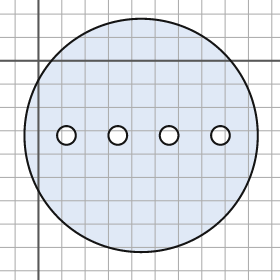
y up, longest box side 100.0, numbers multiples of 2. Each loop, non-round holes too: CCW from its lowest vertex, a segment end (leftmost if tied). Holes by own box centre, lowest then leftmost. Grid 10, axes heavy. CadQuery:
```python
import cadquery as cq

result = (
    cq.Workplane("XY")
    .moveTo(44.0, -32.0)
    .circle(50.0)
    .moveTo(12.0, -32.0)
    .circle(4.0)
    .moveTo(34.0, -32.0)
    .circle(4.0)
    .moveTo(56.0, -32.0)
    .circle(4.0)
    .moveTo(78.0, -32.0)
    .circle(4.0)
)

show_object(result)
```